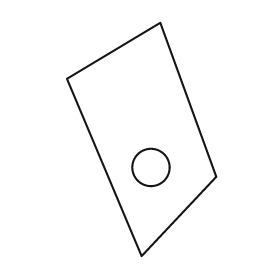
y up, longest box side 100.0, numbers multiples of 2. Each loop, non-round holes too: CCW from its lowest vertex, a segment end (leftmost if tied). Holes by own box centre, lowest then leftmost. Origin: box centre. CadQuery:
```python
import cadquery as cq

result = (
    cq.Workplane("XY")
    .moveTo(0.0, -50.0)
    .lineTo(32.0, -16.0)
    .lineTo(8.0, 50.0)
    .lineTo(-32.0, 26.0)
    .close()
    .moveTo(4.0, -12.0)
    .circle(8.0)
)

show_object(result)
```